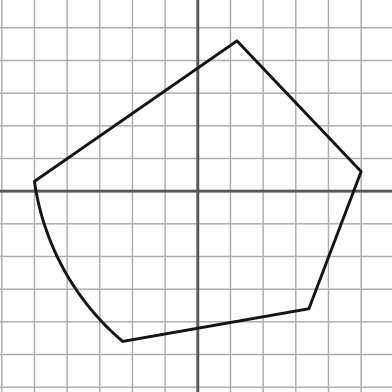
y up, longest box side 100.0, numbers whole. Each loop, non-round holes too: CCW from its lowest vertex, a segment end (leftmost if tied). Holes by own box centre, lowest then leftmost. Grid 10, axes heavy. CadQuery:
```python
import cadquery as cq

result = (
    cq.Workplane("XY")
    .moveTo(-23.0, -46.0)
    .lineTo(34.0, -36.0)
    .lineTo(50.0, 6.0)
    .lineTo(12.0, 46.0)
    .lineTo(-50.0, 3.0)
    .threePointArc((-41.0, -24.0), (-23.0, -46.0))
    .close()
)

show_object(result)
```